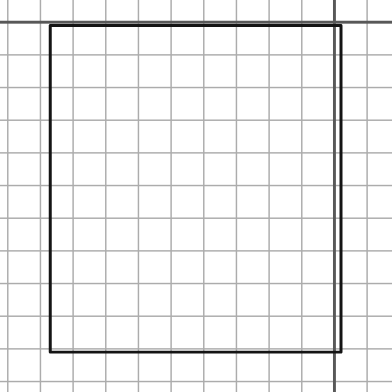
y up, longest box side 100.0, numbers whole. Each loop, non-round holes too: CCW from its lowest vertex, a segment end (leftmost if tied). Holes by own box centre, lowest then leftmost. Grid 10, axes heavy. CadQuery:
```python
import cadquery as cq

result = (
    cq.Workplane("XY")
    .moveTo(-87.0, -101.0)
    .lineTo(2.0, -101.0)
    .lineTo(2.0, -1.0)
    .lineTo(-87.0, -1.0)
    .close()
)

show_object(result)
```